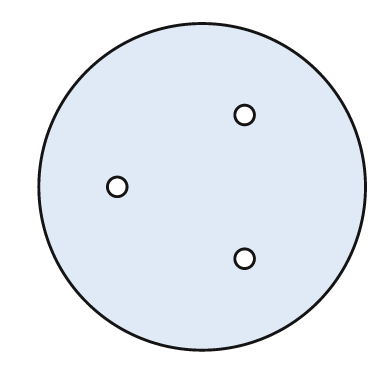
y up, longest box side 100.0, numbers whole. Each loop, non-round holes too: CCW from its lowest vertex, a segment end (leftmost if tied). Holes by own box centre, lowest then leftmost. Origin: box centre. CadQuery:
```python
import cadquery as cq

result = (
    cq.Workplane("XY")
    .moveTo(0.0, 0.0)
    .circle(50.0)
    .moveTo(13.0, -22.0)
    .circle(3.0)
    .moveTo(-26.0, 0.0)
    .circle(3.0)
    .moveTo(13.0, 22.0)
    .circle(3.0)
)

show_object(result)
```